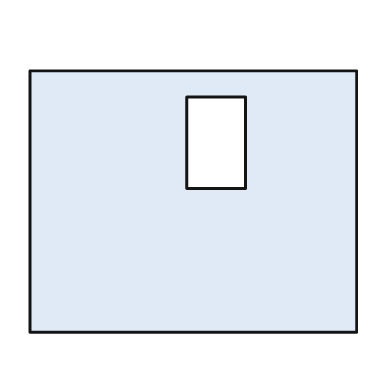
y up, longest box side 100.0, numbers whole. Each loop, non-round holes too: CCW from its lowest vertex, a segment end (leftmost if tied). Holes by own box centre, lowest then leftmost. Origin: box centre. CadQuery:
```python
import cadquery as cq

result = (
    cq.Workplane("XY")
    .moveTo(-50.0, -40.0)
    .lineTo(50.0, -40.0)
    .lineTo(50.0, 40.0)
    .lineTo(-50.0, 40.0)
    .close()
    .moveTo(-2.0, 4.0)
    .lineTo(16.0, 4.0)
    .lineTo(16.0, 32.0)
    .lineTo(-2.0, 32.0)
    .close()
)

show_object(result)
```